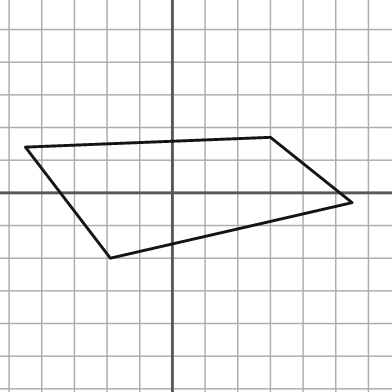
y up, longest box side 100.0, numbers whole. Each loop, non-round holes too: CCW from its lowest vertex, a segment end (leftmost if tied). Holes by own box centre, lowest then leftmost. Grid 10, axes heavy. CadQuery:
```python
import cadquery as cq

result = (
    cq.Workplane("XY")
    .moveTo(-19.0, -20.0)
    .lineTo(55.0, -3.0)
    .lineTo(30.0, 17.0)
    .lineTo(-45.0, 14.0)
    .close()
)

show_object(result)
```